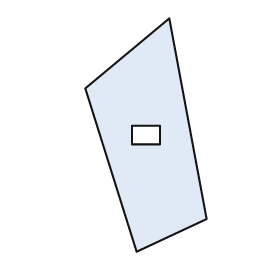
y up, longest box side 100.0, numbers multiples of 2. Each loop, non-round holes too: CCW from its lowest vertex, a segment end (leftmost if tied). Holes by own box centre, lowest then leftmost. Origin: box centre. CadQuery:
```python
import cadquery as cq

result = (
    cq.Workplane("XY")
    .moveTo(-4.0, -50.0)
    .lineTo(26.0, -36.0)
    .lineTo(10.0, 50.0)
    .lineTo(-26.0, 20.0)
    .close()
    .moveTo(-6.0, -4.0)
    .lineTo(6.0, -4.0)
    .lineTo(6.0, 4.0)
    .lineTo(-6.0, 4.0)
    .close()
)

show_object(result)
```